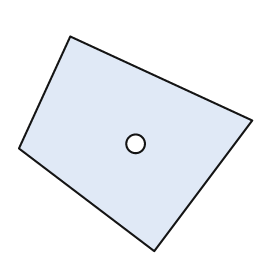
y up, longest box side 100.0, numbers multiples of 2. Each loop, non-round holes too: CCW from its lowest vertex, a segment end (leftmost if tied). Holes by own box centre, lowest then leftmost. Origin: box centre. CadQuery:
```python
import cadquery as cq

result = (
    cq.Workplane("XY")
    .moveTo(8.0, -46.0)
    .lineTo(50.0, 10.0)
    .lineTo(-28.0, 46.0)
    .lineTo(-50.0, -2.0)
    .close()
    .moveTo(0.0, 0.0)
    .circle(4.0)
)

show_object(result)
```